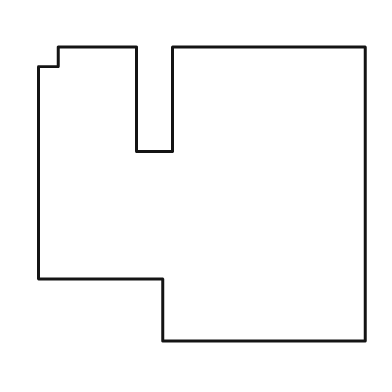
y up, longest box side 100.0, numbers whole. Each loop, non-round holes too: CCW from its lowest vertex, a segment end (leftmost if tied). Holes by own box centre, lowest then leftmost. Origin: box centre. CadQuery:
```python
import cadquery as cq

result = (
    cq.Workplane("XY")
    .moveTo(-12.0, -45.0)
    .lineTo(50.0, -45.0)
    .lineTo(50.0, 45.0)
    .lineTo(-9.0, 45.0)
    .lineTo(-9.0, 13.0)
    .lineTo(-20.0, 13.0)
    .lineTo(-20.0, 45.0)
    .lineTo(-44.0, 45.0)
    .lineTo(-44.0, 39.0)
    .lineTo(-50.0, 39.0)
    .lineTo(-50.0, -26.0)
    .lineTo(-12.0, -26.0)
    .close()
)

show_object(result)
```